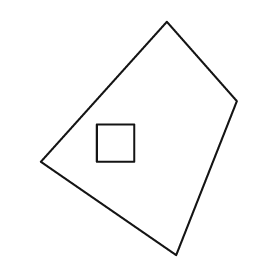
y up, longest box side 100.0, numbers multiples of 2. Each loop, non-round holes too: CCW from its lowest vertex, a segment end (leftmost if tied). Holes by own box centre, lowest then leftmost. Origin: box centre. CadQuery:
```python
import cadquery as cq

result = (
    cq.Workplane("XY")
    .moveTo(16.0, -50.0)
    .lineTo(42.0, 16.0)
    .lineTo(12.0, 50.0)
    .lineTo(-42.0, -10.0)
    .close()
    .moveTo(-18.0, -10.0)
    .lineTo(-2.0, -10.0)
    .lineTo(-2.0, 6.0)
    .lineTo(-18.0, 6.0)
    .close()
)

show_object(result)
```